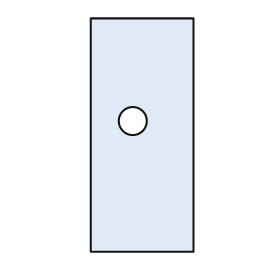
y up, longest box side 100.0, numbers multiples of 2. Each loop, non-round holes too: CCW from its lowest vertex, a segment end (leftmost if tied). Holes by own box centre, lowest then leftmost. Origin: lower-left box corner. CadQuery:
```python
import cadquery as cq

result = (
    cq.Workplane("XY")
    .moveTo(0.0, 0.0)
    .lineTo(44.0, 0.0)
    .lineTo(44.0, 100.0)
    .lineTo(0.0, 100.0)
    .close()
    .moveTo(18.0, 56.0)
    .circle(6.0)
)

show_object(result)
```